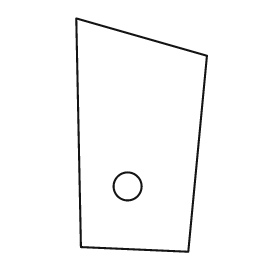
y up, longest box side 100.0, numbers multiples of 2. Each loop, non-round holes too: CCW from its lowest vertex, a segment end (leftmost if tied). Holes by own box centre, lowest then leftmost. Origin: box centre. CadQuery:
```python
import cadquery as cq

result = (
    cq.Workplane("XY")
    .moveTo(20.0, -50.0)
    .lineTo(28.0, 34.0)
    .lineTo(-28.0, 50.0)
    .lineTo(-26.0, -48.0)
    .close()
    .moveTo(-6.0, -22.0)
    .circle(6.0)
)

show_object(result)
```